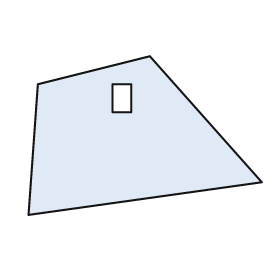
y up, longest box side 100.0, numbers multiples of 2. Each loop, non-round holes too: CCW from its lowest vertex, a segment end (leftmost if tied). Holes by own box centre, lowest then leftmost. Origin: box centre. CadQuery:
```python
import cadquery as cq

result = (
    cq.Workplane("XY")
    .moveTo(-50.0, -34.0)
    .lineTo(50.0, -20.0)
    .lineTo(2.0, 34.0)
    .lineTo(-46.0, 22.0)
    .close()
    .moveTo(-14.0, 10.0)
    .lineTo(-6.0, 10.0)
    .lineTo(-6.0, 22.0)
    .lineTo(-14.0, 22.0)
    .close()
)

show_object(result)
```